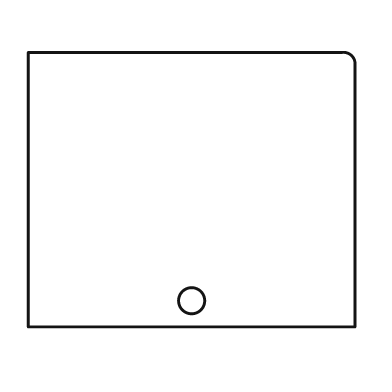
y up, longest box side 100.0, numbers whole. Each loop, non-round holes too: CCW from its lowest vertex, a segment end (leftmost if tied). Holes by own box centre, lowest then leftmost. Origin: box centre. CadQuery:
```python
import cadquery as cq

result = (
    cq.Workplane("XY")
    .moveTo(-50.0, -42.0)
    .lineTo(50.0, -42.0)
    .lineTo(50.0, 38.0)
    .threePointArc((49.0, 41.0), (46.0, 42.0))
    .lineTo(-50.0, 42.0)
    .close()
    .moveTo(0.0, -34.0)
    .circle(4.0)
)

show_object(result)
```